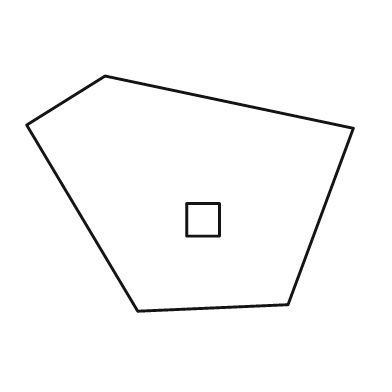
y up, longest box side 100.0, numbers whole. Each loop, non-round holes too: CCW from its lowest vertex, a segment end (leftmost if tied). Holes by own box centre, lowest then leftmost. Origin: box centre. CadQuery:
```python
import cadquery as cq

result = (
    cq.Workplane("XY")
    .moveTo(-16.0, -36.0)
    .lineTo(30.0, -34.0)
    .lineTo(50.0, 20.0)
    .lineTo(-26.0, 36.0)
    .lineTo(-50.0, 21.0)
    .close()
    .moveTo(-1.0, -13.0)
    .lineTo(9.0, -13.0)
    .lineTo(9.0, -3.0)
    .lineTo(-1.0, -3.0)
    .close()
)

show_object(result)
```